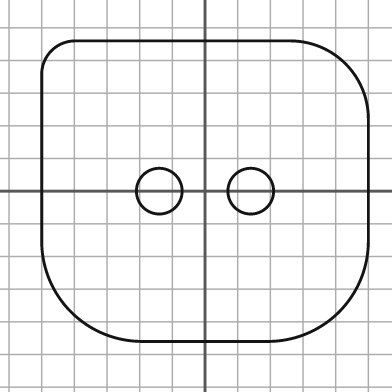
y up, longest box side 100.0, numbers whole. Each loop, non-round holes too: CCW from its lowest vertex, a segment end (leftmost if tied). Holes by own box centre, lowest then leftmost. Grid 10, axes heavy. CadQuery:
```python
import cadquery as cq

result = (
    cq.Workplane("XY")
    .moveTo(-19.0, -46.0)
    .lineTo(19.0, -46.0)
    .threePointArc((41.0, -37.0), (50.0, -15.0))
    .lineTo(50.0, 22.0)
    .threePointArc((43.0, 39.0), (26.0, 46.0))
    .lineTo(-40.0, 46.0)
    .threePointArc((-47.0, 43.0), (-50.0, 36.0))
    .lineTo(-50.0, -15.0)
    .threePointArc((-41.0, -37.0), (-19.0, -46.0))
    .close()
    .moveTo(-14.0, 0.0)
    .circle(7.0)
    .moveTo(14.0, 0.0)
    .circle(7.0)
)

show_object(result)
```